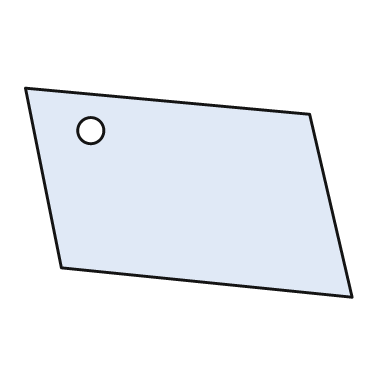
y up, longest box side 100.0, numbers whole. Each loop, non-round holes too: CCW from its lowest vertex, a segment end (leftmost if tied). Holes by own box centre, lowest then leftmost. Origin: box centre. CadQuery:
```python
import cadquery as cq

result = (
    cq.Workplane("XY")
    .moveTo(50.0, -32.0)
    .lineTo(37.0, 24.0)
    .lineTo(-50.0, 32.0)
    .lineTo(-39.0, -23.0)
    .close()
    .moveTo(-30.0, 19.0)
    .circle(4.0)
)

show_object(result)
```